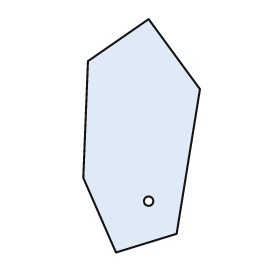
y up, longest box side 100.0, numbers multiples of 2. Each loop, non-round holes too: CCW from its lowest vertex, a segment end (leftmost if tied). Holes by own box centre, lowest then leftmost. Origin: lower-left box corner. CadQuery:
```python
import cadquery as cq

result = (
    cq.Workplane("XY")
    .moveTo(14.0, 0.0)
    .lineTo(40.0, 8.0)
    .lineTo(50.0, 70.0)
    .lineTo(28.0, 100.0)
    .lineTo(2.0, 82.0)
    .lineTo(0.0, 32.0)
    .close()
    .moveTo(28.0, 22.0)
    .circle(2.0)
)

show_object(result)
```